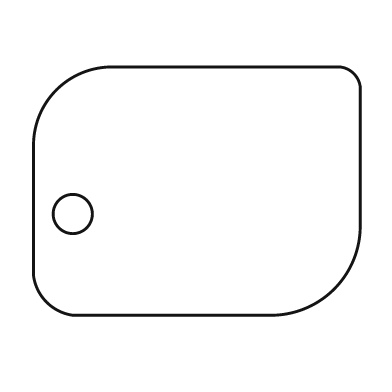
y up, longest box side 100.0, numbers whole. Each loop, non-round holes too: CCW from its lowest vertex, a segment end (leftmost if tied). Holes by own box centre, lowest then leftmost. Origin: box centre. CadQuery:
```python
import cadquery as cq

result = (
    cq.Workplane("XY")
    .moveTo(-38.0, -38.0)
    .lineTo(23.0, -38.0)
    .threePointArc((42.0, -30.0), (50.0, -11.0))
    .lineTo(50.0, 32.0)
    .threePointArc((48.0, 36.0), (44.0, 38.0))
    .lineTo(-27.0, 38.0)
    .threePointArc((-43.0, 31.0), (-50.0, 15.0))
    .lineTo(-50.0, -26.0)
    .threePointArc((-46.0, -34.0), (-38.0, -38.0))
    .close()
    .moveTo(-38.0, -7.0)
    .circle(6.0)
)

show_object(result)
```